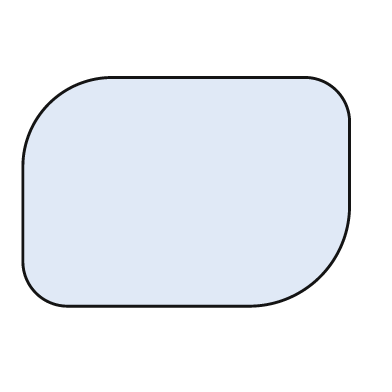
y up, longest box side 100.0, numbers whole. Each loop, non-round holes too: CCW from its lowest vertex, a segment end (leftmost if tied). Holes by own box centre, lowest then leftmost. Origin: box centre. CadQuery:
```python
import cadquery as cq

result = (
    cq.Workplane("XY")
    .moveTo(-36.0, -35.0)
    .lineTo(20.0, -35.0)
    .threePointArc((41.0, -26.0), (50.0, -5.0))
    .lineTo(50.0, 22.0)
    .threePointArc((46.0, 31.0), (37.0, 35.0))
    .lineTo(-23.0, 35.0)
    .threePointArc((-42.0, 27.0), (-50.0, 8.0))
    .lineTo(-50.0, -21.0)
    .threePointArc((-46.0, -31.0), (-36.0, -35.0))
    .close()
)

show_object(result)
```